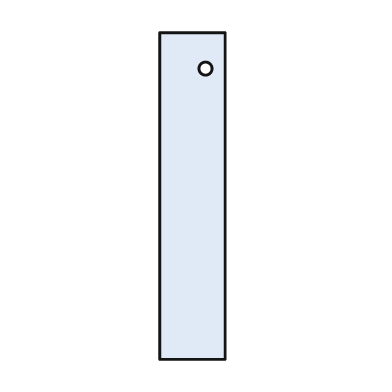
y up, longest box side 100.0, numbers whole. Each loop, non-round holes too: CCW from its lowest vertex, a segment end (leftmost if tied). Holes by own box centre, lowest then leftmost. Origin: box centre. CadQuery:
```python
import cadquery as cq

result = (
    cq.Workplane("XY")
    .moveTo(-10.0, -50.0)
    .lineTo(10.0, -50.0)
    .lineTo(10.0, 50.0)
    .lineTo(-10.0, 50.0)
    .close()
    .moveTo(4.0, 39.0)
    .circle(2.0)
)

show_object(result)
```